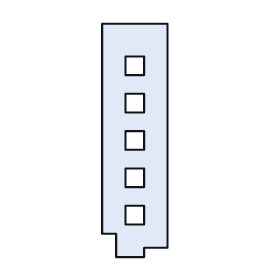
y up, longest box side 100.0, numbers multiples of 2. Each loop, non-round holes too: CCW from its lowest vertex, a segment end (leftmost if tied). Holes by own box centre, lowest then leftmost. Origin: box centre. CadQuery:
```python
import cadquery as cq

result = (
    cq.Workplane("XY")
    .moveTo(-8.0, -50.0)
    .lineTo(4.0, -50.0)
    .lineTo(4.0, -46.0)
    .lineTo(14.0, -46.0)
    .lineTo(14.0, 50.0)
    .lineTo(-14.0, 50.0)
    .lineTo(-14.0, -40.0)
    .lineTo(-8.0, -40.0)
    .close()
    .moveTo(-4.0, -36.0)
    .lineTo(4.0, -36.0)
    .lineTo(4.0, -28.0)
    .lineTo(-4.0, -28.0)
    .close()
    .moveTo(-4.0, -20.0)
    .lineTo(4.0, -20.0)
    .lineTo(4.0, -12.0)
    .lineTo(-4.0, -12.0)
    .close()
    .moveTo(-4.0, -4.0)
    .lineTo(4.0, -4.0)
    .lineTo(4.0, 4.0)
    .lineTo(-4.0, 4.0)
    .close()
    .moveTo(-4.0, 12.0)
    .lineTo(4.0, 12.0)
    .lineTo(4.0, 20.0)
    .lineTo(-4.0, 20.0)
    .close()
    .moveTo(-4.0, 28.0)
    .lineTo(4.0, 28.0)
    .lineTo(4.0, 36.0)
    .lineTo(-4.0, 36.0)
    .close()
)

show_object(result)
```